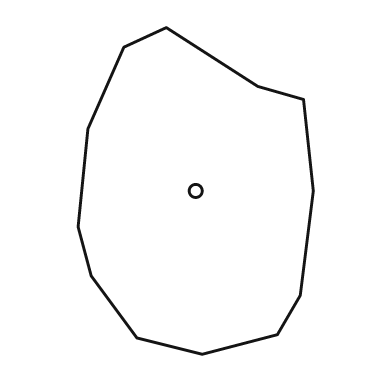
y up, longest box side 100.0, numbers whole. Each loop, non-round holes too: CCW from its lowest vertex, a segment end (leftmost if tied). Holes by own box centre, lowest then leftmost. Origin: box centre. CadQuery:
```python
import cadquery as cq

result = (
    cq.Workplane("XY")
    .moveTo(2.0, -50.0)
    .lineTo(25.0, -44.0)
    .lineTo(32.0, -32.0)
    .lineTo(36.0, 0.0)
    .lineTo(33.0, 28.0)
    .lineTo(19.0, 32.0)
    .lineTo(-9.0, 50.0)
    .lineTo(-22.0, 44.0)
    .lineTo(-33.0, 19.0)
    .lineTo(-36.0, -11.0)
    .lineTo(-32.0, -26.0)
    .lineTo(-18.0, -45.0)
    .close()
    .moveTo(0.0, 0.0)
    .circle(2.0)
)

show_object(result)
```